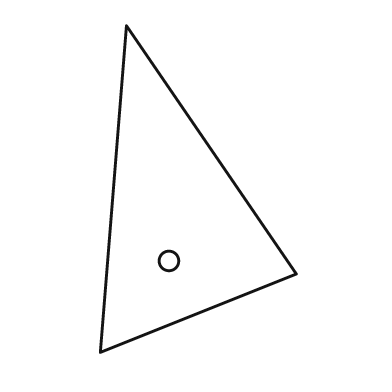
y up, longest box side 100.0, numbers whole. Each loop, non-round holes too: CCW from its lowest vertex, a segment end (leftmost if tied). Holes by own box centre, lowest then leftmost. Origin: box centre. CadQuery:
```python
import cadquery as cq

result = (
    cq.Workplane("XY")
    .moveTo(-30.0, -50.0)
    .lineTo(30.0, -26.0)
    .lineTo(-22.0, 50.0)
    .close()
    .moveTo(-9.0, -22.0)
    .circle(3.0)
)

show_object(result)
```